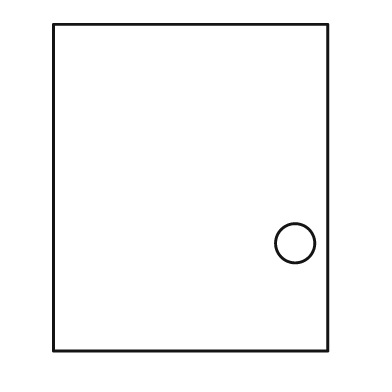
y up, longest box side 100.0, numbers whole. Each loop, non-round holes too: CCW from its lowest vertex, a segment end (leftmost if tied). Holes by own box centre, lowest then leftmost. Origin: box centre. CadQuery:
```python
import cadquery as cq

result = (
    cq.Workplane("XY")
    .moveTo(-42.0, -50.0)
    .lineTo(42.0, -50.0)
    .lineTo(42.0, 50.0)
    .lineTo(-42.0, 50.0)
    .close()
    .moveTo(32.0, -17.0)
    .circle(6.0)
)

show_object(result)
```